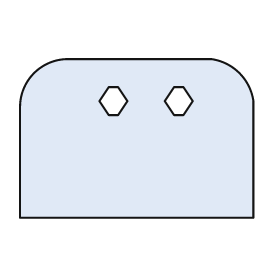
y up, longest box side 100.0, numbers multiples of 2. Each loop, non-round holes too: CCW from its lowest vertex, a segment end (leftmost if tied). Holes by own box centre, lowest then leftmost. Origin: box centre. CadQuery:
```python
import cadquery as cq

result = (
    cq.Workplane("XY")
    .moveTo(-50.0, -34.0)
    .lineTo(50.0, -34.0)
    .lineTo(50.0, 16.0)
    .threePointArc((44.0, 28.0), (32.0, 34.0))
    .lineTo(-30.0, 34.0)
    .threePointArc((-44.0, 28.0), (-50.0, 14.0))
    .close()
    .moveTo(-12.0, 10.0)
    .lineTo(-8.0, 10.0)
    .lineTo(-4.0, 16.0)
    .lineTo(-8.0, 22.0)
    .lineTo(-12.0, 22.0)
    .lineTo(-16.0, 16.0)
    .close()
    .moveTo(16.0, 10.0)
    .lineTo(20.0, 10.0)
    .lineTo(24.0, 16.0)
    .lineTo(20.0, 22.0)
    .lineTo(16.0, 22.0)
    .lineTo(12.0, 16.0)
    .close()
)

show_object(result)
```